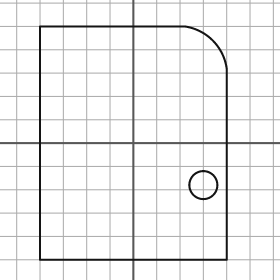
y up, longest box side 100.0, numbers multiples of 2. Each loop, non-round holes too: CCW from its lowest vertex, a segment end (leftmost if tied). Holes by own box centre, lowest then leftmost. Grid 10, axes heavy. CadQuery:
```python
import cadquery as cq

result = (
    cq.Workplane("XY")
    .moveTo(-40.0, -50.0)
    .lineTo(40.0, -50.0)
    .lineTo(40.0, 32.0)
    .threePointArc((34.0, 44.0), (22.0, 50.0))
    .lineTo(-40.0, 50.0)
    .close()
    .moveTo(30.0, -18.0)
    .circle(6.0)
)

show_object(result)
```